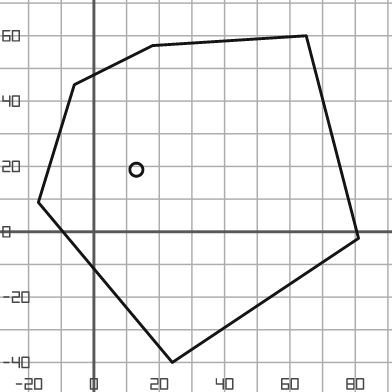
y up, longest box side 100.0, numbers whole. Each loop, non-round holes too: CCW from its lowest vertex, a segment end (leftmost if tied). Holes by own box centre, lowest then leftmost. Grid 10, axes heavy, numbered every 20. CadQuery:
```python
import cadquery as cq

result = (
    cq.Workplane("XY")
    .moveTo(24.0, -40.0)
    .lineTo(81.0, -2.0)
    .lineTo(65.0, 60.0)
    .lineTo(18.0, 57.0)
    .lineTo(-6.0, 45.0)
    .lineTo(-17.0, 9.0)
    .close()
    .moveTo(13.0, 19.0)
    .circle(2.0)
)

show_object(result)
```